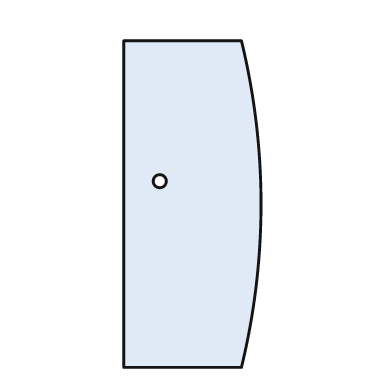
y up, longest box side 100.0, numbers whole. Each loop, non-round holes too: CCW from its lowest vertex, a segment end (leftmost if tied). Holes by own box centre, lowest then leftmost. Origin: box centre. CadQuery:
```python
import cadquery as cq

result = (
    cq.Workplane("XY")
    .moveTo(-21.0, -50.0)
    .lineTo(15.0, -50.0)
    .threePointArc((21.0, 0.0), (15.0, 50.0))
    .lineTo(-21.0, 50.0)
    .close()
    .moveTo(-10.0, 7.0)
    .circle(2.0)
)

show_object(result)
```